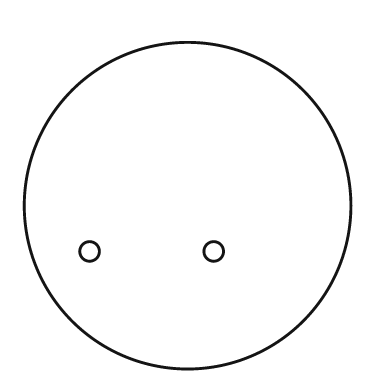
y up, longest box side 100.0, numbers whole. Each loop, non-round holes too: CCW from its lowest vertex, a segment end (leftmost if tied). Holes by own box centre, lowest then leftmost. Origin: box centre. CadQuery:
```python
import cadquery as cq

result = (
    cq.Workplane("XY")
    .moveTo(0.0, 0.0)
    .circle(50.0)
    .moveTo(-30.0, -14.0)
    .circle(3.0)
    .moveTo(8.0, -14.0)
    .circle(3.0)
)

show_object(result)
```